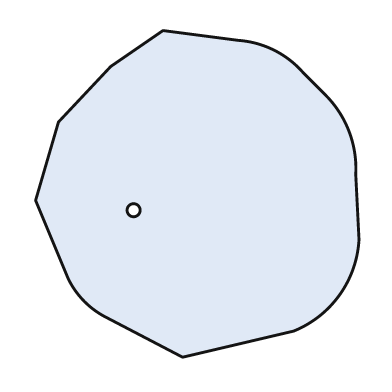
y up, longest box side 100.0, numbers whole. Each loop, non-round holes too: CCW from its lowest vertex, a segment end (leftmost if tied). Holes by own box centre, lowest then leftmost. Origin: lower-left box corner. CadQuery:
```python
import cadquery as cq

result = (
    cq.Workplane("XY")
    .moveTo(45.0, 0.0)
    .lineTo(79.0, 8.0)
    .threePointArc((93.0, 19.0), (99.0, 36.0))
    .lineTo(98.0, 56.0)
    .threePointArc((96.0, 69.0), (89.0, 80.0))
    .lineTo(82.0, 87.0)
    .threePointArc((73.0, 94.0), (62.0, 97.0))
    .lineTo(39.0, 100.0)
    .lineTo(23.0, 89.0)
    .lineTo(7.0, 72.0)
    .lineTo(0.0, 48.0)
    .lineTo(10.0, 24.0)
    .threePointArc((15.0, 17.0), (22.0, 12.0))
    .close()
    .moveTo(30.0, 45.0)
    .circle(2.0)
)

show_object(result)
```